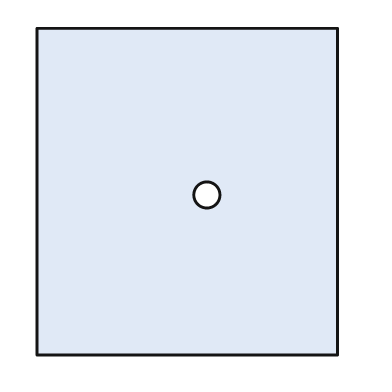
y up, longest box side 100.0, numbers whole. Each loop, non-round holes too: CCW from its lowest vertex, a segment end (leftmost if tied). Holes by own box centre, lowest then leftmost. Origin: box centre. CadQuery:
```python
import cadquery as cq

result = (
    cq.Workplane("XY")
    .moveTo(-46.0, -50.0)
    .lineTo(46.0, -50.0)
    .lineTo(46.0, 50.0)
    .lineTo(-46.0, 50.0)
    .close()
    .moveTo(6.0, -1.0)
    .circle(4.0)
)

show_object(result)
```